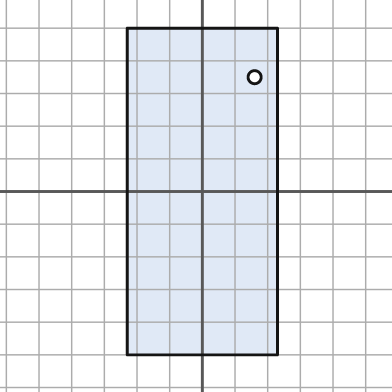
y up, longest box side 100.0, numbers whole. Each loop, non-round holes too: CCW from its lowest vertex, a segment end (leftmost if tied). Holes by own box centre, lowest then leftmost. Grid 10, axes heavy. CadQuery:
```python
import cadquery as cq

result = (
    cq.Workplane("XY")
    .moveTo(-23.0, -50.0)
    .lineTo(23.0, -50.0)
    .lineTo(23.0, 50.0)
    .lineTo(-23.0, 50.0)
    .close()
    .moveTo(16.0, 35.0)
    .circle(2.0)
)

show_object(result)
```